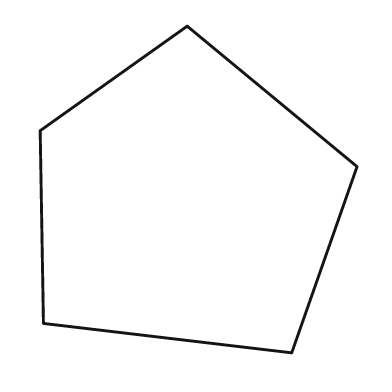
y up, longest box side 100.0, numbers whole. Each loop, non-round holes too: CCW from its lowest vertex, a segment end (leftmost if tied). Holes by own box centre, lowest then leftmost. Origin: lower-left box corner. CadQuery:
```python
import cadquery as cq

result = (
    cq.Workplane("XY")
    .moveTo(77.0, 0.0)
    .lineTo(97.0, 57.0)
    .lineTo(45.0, 100.0)
    .lineTo(0.0, 68.0)
    .lineTo(1.0, 9.0)
    .close()
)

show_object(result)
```